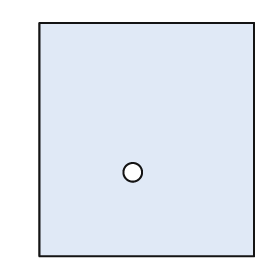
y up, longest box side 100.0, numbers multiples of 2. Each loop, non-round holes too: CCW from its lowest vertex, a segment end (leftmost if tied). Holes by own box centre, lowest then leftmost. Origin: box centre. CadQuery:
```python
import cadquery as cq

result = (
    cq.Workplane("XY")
    .moveTo(-46.0, -50.0)
    .lineTo(46.0, -50.0)
    .lineTo(46.0, 50.0)
    .lineTo(-46.0, 50.0)
    .close()
    .moveTo(-6.0, -14.0)
    .circle(4.0)
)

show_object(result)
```